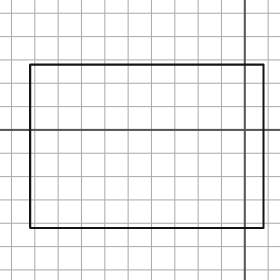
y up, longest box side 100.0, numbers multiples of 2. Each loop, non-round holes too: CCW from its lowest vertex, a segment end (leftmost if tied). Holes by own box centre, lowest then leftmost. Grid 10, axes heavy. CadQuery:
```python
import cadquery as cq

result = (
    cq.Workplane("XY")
    .moveTo(-92.0, -42.0)
    .lineTo(8.0, -42.0)
    .lineTo(8.0, 28.0)
    .lineTo(-92.0, 28.0)
    .close()
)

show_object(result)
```